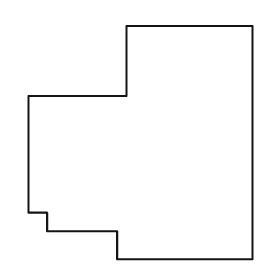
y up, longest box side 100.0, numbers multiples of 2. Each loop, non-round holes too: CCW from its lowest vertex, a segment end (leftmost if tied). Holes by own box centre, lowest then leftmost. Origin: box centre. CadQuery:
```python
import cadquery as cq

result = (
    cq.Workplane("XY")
    .moveTo(-10.0, -50.0)
    .lineTo(48.0, -50.0)
    .lineTo(48.0, 50.0)
    .lineTo(-6.0, 50.0)
    .lineTo(-6.0, 20.0)
    .lineTo(-48.0, 20.0)
    .lineTo(-48.0, -30.0)
    .lineTo(-40.0, -30.0)
    .lineTo(-40.0, -38.0)
    .lineTo(-10.0, -38.0)
    .close()
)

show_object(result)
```